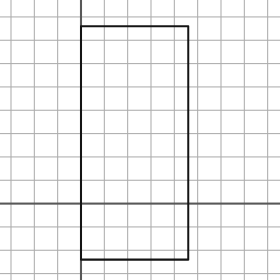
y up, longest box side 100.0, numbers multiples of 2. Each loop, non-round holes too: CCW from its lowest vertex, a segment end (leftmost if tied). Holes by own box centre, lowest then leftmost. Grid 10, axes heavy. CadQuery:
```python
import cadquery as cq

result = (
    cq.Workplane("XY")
    .moveTo(0.0, -24.0)
    .lineTo(46.0, -24.0)
    .lineTo(46.0, 76.0)
    .lineTo(0.0, 76.0)
    .close()
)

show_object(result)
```